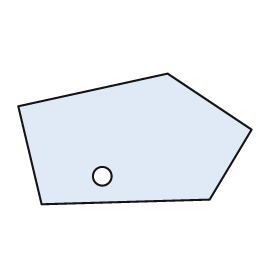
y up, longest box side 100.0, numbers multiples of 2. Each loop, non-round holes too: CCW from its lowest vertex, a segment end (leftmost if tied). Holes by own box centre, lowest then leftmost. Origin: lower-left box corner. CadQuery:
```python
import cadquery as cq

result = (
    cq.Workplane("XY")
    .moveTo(10.0, 0.0)
    .lineTo(82.0, 2.0)
    .lineTo(100.0, 32.0)
    .lineTo(64.0, 56.0)
    .lineTo(0.0, 42.0)
    .close()
    .moveTo(36.0, 12.0)
    .circle(4.0)
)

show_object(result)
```